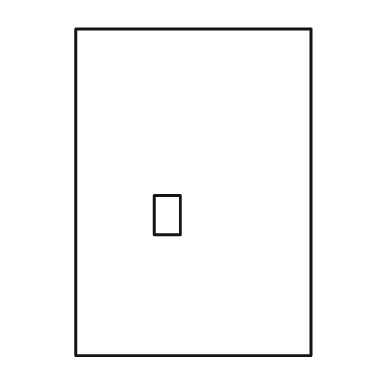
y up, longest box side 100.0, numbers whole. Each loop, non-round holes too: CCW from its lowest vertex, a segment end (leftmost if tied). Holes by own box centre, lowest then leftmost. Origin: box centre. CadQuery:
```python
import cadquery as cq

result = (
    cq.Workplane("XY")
    .moveTo(-36.0, -50.0)
    .lineTo(36.0, -50.0)
    .lineTo(36.0, 50.0)
    .lineTo(-36.0, 50.0)
    .close()
    .moveTo(-12.0, -13.0)
    .lineTo(-4.0, -13.0)
    .lineTo(-4.0, -1.0)
    .lineTo(-12.0, -1.0)
    .close()
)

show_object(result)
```